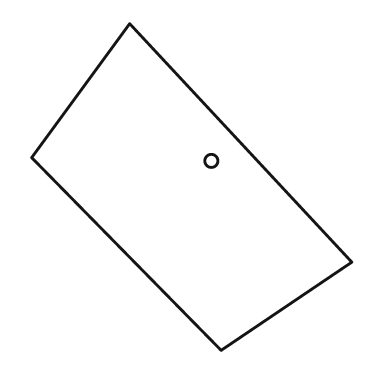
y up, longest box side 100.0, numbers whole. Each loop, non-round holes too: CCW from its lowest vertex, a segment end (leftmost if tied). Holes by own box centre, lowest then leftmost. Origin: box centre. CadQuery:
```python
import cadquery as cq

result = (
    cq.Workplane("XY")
    .moveTo(9.0, -50.0)
    .lineTo(49.0, -23.0)
    .lineTo(-19.0, 50.0)
    .lineTo(-49.0, 9.0)
    .close()
    .moveTo(6.0, 8.0)
    .circle(2.0)
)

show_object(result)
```